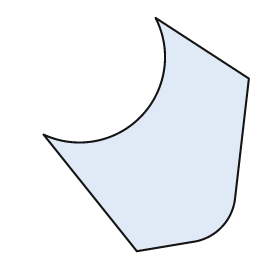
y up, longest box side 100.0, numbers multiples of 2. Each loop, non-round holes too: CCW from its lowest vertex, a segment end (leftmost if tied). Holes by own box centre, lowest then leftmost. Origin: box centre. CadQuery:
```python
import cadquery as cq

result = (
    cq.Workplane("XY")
    .moveTo(-4.0, -50.0)
    .lineTo(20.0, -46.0)
    .threePointArc((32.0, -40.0), (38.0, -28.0))
    .lineTo(44.0, 24.0)
    .lineTo(4.0, 50.0)
    .threePointArc((-2.0, 8.0), (-44.0, 0.0))
    .close()
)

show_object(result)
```